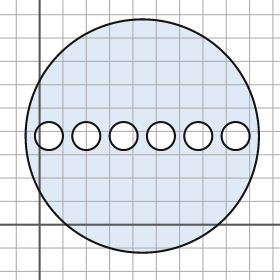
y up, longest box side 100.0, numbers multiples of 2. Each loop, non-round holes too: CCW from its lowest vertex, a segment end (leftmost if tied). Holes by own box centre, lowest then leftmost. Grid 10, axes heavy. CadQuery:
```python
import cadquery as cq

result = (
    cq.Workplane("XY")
    .moveTo(44.0, 38.0)
    .circle(50.0)
    .moveTo(4.0, 38.0)
    .circle(6.0)
    .moveTo(20.0, 38.0)
    .circle(6.0)
    .moveTo(36.0, 38.0)
    .circle(6.0)
    .moveTo(52.0, 38.0)
    .circle(6.0)
    .moveTo(68.0, 38.0)
    .circle(6.0)
    .moveTo(84.0, 38.0)
    .circle(6.0)
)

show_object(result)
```